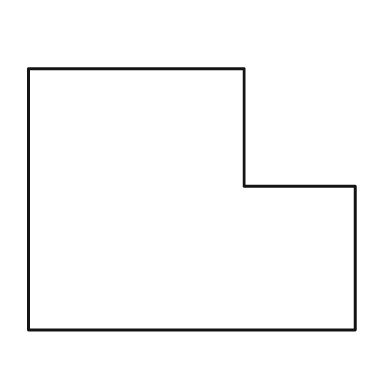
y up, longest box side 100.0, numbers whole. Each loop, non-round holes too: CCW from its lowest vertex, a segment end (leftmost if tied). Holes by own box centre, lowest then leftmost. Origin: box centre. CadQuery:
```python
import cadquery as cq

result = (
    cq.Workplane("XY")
    .moveTo(-50.0, -40.0)
    .lineTo(50.0, -40.0)
    .lineTo(50.0, 4.0)
    .lineTo(16.0, 4.0)
    .lineTo(16.0, 40.0)
    .lineTo(-50.0, 40.0)
    .close()
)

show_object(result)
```